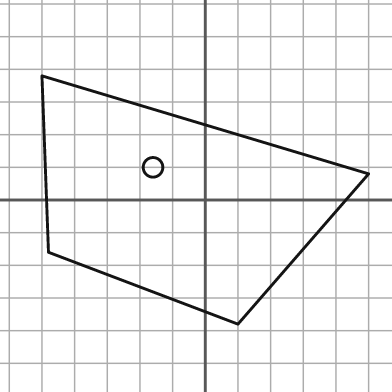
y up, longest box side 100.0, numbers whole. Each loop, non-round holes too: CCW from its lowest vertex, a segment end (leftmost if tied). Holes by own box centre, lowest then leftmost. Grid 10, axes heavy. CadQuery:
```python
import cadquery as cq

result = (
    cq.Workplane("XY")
    .moveTo(10.0, -38.0)
    .lineTo(50.0, 8.0)
    .lineTo(-50.0, 38.0)
    .lineTo(-48.0, -16.0)
    .close()
    .moveTo(-16.0, 10.0)
    .circle(3.0)
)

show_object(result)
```